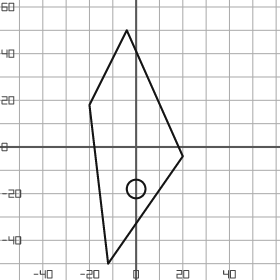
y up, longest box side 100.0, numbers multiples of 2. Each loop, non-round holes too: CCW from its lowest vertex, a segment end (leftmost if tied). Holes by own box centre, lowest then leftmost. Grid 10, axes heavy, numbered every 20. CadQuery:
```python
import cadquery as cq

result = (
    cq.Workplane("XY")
    .moveTo(-12.0, -50.0)
    .lineTo(20.0, -4.0)
    .lineTo(-4.0, 50.0)
    .lineTo(-20.0, 18.0)
    .close()
    .moveTo(0.0, -18.0)
    .circle(4.0)
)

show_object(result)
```